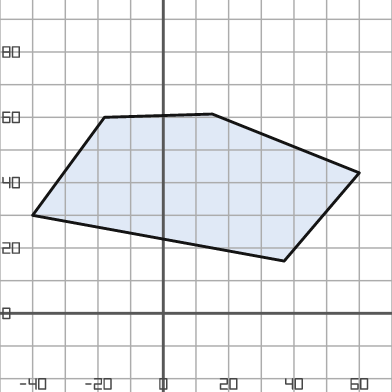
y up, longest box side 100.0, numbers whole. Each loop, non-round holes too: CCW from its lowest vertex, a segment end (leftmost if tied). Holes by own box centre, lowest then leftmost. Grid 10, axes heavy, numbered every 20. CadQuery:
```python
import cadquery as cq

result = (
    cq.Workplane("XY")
    .moveTo(37.0, 16.0)
    .lineTo(60.0, 43.0)
    .lineTo(15.0, 61.0)
    .lineTo(-18.0, 60.0)
    .lineTo(-40.0, 30.0)
    .close()
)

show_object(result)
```